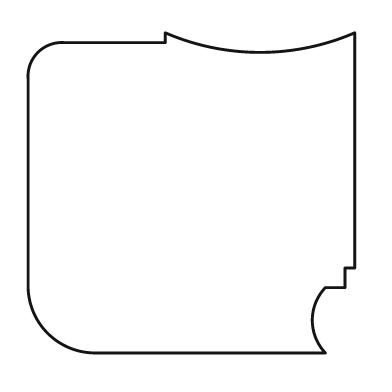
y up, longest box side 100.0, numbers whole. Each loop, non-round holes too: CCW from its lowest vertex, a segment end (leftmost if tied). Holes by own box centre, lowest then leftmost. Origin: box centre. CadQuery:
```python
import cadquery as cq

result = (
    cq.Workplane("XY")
    .moveTo(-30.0, -49.0)
    .lineTo(41.0, -49.0)
    .threePointArc((37.0, -39.0), (41.0, -29.0))
    .lineTo(47.0, -29.0)
    .lineTo(47.0, -23.0)
    .lineTo(50.0, -23.0)
    .lineTo(50.0, 49.0)
    .threePointArc((21.0, 43.0), (-8.0, 49.0))
    .lineTo(-8.0, 46.0)
    .lineTo(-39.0, 46.0)
    .threePointArc((-47.0, 43.0), (-50.0, 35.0))
    .lineTo(-50.0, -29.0)
    .threePointArc((-44.0, -43.0), (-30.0, -49.0))
    .close()
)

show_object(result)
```